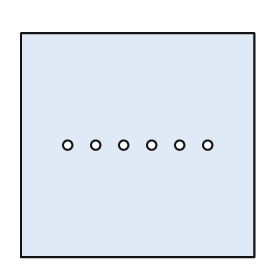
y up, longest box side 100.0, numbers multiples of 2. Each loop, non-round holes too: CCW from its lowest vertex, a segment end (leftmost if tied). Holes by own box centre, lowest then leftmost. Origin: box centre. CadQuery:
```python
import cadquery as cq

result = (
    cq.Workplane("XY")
    .moveTo(-50.0, -48.0)
    .lineTo(50.0, -48.0)
    .lineTo(50.0, 48.0)
    .lineTo(-50.0, 48.0)
    .close()
    .moveTo(-30.0, 0.0)
    .circle(2.0)
    .moveTo(-18.0, 0.0)
    .circle(2.0)
    .moveTo(-6.0, 0.0)
    .circle(2.0)
    .moveTo(6.0, 0.0)
    .circle(2.0)
    .moveTo(18.0, 0.0)
    .circle(2.0)
    .moveTo(30.0, 0.0)
    .circle(2.0)
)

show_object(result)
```